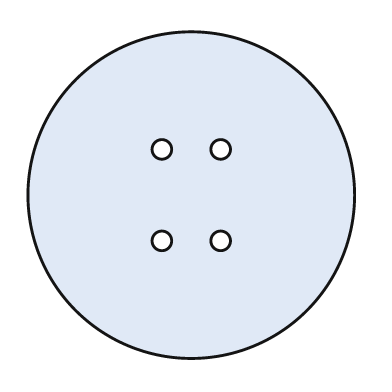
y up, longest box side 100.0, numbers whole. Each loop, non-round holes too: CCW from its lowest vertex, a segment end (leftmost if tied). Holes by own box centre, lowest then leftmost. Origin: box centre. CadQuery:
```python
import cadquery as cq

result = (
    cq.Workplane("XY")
    .moveTo(0.0, 0.0)
    .circle(50.0)
    .moveTo(-9.0, -14.0)
    .circle(3.0)
    .moveTo(9.0, -14.0)
    .circle(3.0)
    .moveTo(-9.0, 14.0)
    .circle(3.0)
    .moveTo(9.0, 14.0)
    .circle(3.0)
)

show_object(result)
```